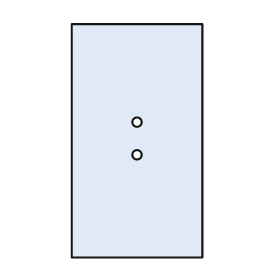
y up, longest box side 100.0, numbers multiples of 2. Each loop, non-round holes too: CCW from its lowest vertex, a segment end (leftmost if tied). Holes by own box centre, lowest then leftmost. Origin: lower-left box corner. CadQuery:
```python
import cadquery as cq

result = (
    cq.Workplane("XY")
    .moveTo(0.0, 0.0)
    .lineTo(56.0, 0.0)
    .lineTo(56.0, 100.0)
    .lineTo(0.0, 100.0)
    .close()
    .moveTo(28.0, 44.0)
    .circle(2.0)
    .moveTo(28.0, 58.0)
    .circle(2.0)
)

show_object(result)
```